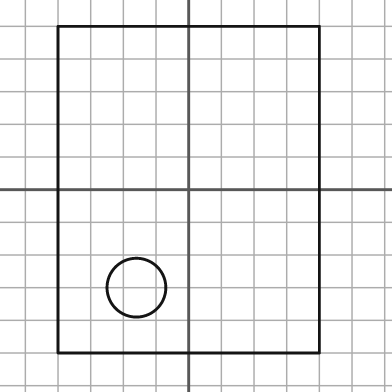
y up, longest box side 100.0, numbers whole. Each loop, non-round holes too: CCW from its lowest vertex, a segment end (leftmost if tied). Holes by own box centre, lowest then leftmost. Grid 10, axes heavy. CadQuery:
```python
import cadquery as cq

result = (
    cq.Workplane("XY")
    .moveTo(-40.0, -50.0)
    .lineTo(40.0, -50.0)
    .lineTo(40.0, 50.0)
    .lineTo(-40.0, 50.0)
    .close()
    .moveTo(-16.0, -30.0)
    .circle(9.0)
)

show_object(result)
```